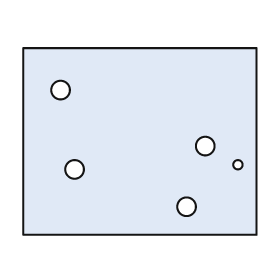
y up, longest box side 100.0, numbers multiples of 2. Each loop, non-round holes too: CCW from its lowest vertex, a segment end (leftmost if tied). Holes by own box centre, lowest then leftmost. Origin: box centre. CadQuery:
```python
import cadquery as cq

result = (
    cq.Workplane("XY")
    .moveTo(-50.0, -40.0)
    .lineTo(50.0, -40.0)
    .lineTo(50.0, 40.0)
    .lineTo(-50.0, 40.0)
    .close()
    .moveTo(20.0, -28.0)
    .circle(4.0)
    .moveTo(-28.0, -12.0)
    .circle(4.0)
    .moveTo(42.0, -10.0)
    .circle(2.0)
    .moveTo(28.0, -2.0)
    .circle(4.0)
    .moveTo(-34.0, 22.0)
    .circle(4.0)
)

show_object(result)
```